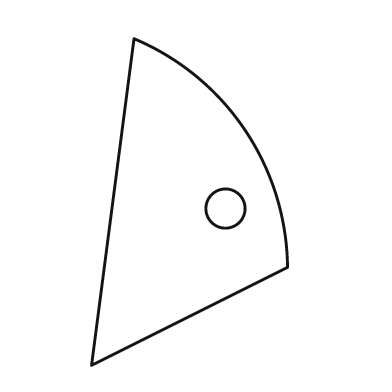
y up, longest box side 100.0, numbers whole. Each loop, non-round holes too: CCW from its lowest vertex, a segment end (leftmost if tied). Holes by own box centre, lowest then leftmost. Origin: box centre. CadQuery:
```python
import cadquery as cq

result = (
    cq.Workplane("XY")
    .moveTo(-30.0, -50.0)
    .lineTo(30.0, -20.0)
    .threePointArc((17.0, 22.0), (-17.0, 50.0))
    .close()
    .moveTo(11.0, -2.0)
    .circle(6.0)
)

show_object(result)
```